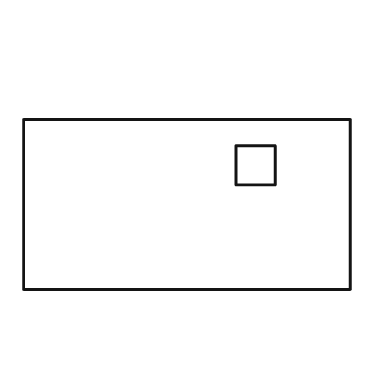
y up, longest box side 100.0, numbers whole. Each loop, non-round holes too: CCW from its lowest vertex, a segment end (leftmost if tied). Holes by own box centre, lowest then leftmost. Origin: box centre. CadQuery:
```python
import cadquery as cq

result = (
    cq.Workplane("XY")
    .moveTo(-50.0, -26.0)
    .lineTo(50.0, -26.0)
    .lineTo(50.0, 26.0)
    .lineTo(-50.0, 26.0)
    .close()
    .moveTo(15.0, 6.0)
    .lineTo(27.0, 6.0)
    .lineTo(27.0, 18.0)
    .lineTo(15.0, 18.0)
    .close()
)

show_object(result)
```